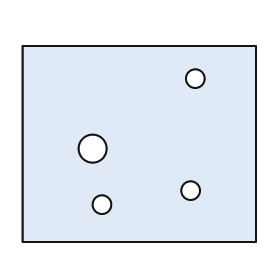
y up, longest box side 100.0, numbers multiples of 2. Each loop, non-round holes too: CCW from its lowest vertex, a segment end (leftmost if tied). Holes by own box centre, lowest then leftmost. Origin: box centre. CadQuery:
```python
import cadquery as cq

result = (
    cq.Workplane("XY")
    .moveTo(-50.0, -42.0)
    .lineTo(50.0, -42.0)
    .lineTo(50.0, 42.0)
    .lineTo(-50.0, 42.0)
    .close()
    .moveTo(-16.0, -26.0)
    .circle(4.0)
    .moveTo(22.0, -20.0)
    .circle(4.0)
    .moveTo(-20.0, -2.0)
    .circle(6.0)
    .moveTo(24.0, 28.0)
    .circle(4.0)
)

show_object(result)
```